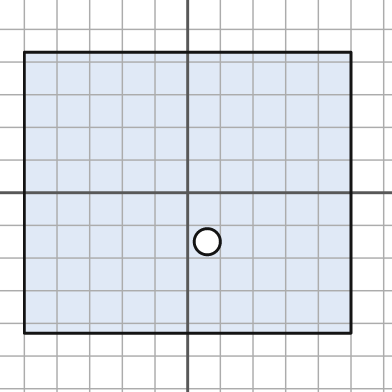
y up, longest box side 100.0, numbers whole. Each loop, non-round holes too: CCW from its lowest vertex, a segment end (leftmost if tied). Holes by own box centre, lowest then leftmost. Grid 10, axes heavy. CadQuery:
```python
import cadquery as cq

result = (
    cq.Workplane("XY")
    .moveTo(-50.0, -43.0)
    .lineTo(50.0, -43.0)
    .lineTo(50.0, 43.0)
    .lineTo(-50.0, 43.0)
    .close()
    .moveTo(6.0, -15.0)
    .circle(4.0)
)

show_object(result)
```